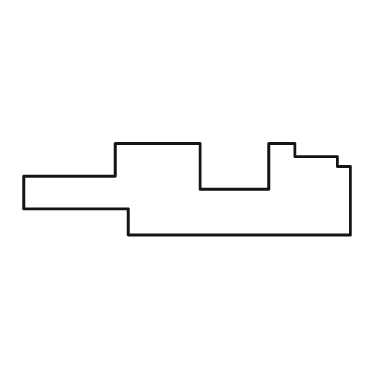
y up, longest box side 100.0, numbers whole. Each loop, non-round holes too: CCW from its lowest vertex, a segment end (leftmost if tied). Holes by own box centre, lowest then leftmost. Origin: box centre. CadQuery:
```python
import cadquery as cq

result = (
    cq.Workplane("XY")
    .moveTo(-18.0, -14.0)
    .lineTo(50.0, -14.0)
    .lineTo(50.0, 7.0)
    .lineTo(46.0, 7.0)
    .lineTo(46.0, 10.0)
    .lineTo(33.0, 10.0)
    .lineTo(33.0, 14.0)
    .lineTo(25.0, 14.0)
    .lineTo(25.0, 0.0)
    .lineTo(4.0, 0.0)
    .lineTo(4.0, 14.0)
    .lineTo(-22.0, 14.0)
    .lineTo(-22.0, 4.0)
    .lineTo(-50.0, 4.0)
    .lineTo(-50.0, -6.0)
    .lineTo(-18.0, -6.0)
    .close()
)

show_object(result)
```